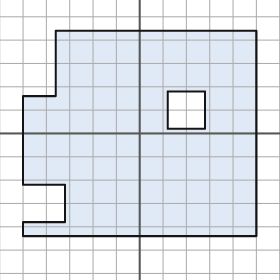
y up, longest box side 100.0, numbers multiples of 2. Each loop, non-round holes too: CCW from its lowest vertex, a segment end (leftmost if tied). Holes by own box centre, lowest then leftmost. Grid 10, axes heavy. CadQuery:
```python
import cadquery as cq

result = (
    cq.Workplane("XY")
    .moveTo(-50.0, -44.0)
    .lineTo(50.0, -44.0)
    .lineTo(50.0, 44.0)
    .lineTo(-36.0, 44.0)
    .lineTo(-36.0, 16.0)
    .lineTo(-50.0, 16.0)
    .lineTo(-50.0, -22.0)
    .lineTo(-32.0, -22.0)
    .lineTo(-32.0, -38.0)
    .lineTo(-50.0, -38.0)
    .close()
    .moveTo(12.0, 2.0)
    .lineTo(28.0, 2.0)
    .lineTo(28.0, 18.0)
    .lineTo(12.0, 18.0)
    .close()
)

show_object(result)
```